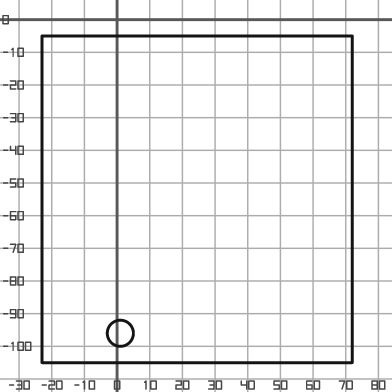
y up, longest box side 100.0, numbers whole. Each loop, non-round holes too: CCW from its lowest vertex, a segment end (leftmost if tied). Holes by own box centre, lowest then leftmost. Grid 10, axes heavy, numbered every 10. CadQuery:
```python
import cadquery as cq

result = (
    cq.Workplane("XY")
    .moveTo(-23.0, -105.0)
    .lineTo(72.0, -105.0)
    .lineTo(72.0, -5.0)
    .lineTo(-23.0, -5.0)
    .close()
    .moveTo(1.0, -96.0)
    .circle(4.0)
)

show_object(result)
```